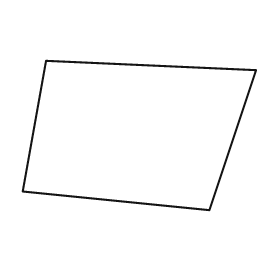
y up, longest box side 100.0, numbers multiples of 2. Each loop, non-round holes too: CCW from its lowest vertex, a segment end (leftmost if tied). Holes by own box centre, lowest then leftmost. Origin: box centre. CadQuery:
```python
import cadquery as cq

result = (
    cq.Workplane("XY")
    .moveTo(30.0, -32.0)
    .lineTo(50.0, 28.0)
    .lineTo(-40.0, 32.0)
    .lineTo(-50.0, -24.0)
    .close()
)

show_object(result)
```